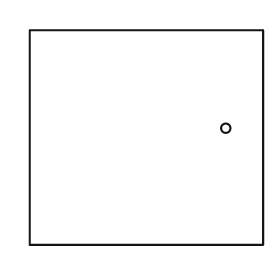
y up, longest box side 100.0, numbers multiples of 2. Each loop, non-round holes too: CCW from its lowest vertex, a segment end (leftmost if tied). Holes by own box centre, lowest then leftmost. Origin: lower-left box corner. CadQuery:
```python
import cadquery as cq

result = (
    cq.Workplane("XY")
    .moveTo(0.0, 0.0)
    .lineTo(100.0, 0.0)
    .lineTo(100.0, 92.0)
    .lineTo(0.0, 92.0)
    .close()
    .moveTo(84.0, 50.0)
    .circle(2.0)
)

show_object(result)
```